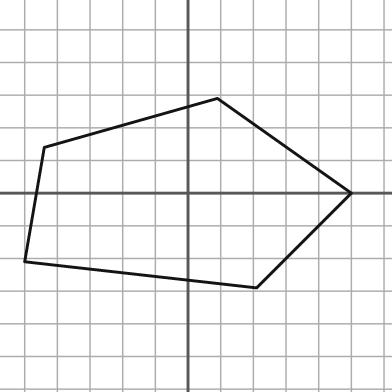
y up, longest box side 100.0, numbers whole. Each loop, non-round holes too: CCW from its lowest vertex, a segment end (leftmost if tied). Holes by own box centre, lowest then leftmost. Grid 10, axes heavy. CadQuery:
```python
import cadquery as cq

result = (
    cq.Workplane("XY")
    .moveTo(21.0, -29.0)
    .lineTo(50.0, 0.0)
    .lineTo(9.0, 29.0)
    .lineTo(-44.0, 14.0)
    .lineTo(-50.0, -21.0)
    .close()
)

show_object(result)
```